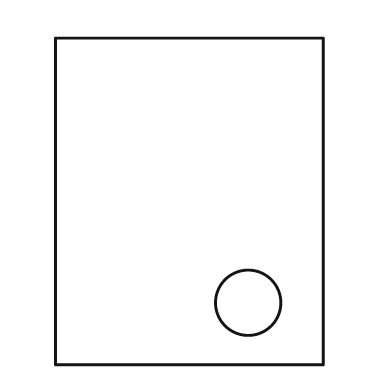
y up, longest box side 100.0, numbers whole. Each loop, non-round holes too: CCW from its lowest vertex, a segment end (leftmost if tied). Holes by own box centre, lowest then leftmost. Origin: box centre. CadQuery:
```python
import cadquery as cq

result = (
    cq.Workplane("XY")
    .moveTo(-41.0, -50.0)
    .lineTo(41.0, -50.0)
    .lineTo(41.0, 50.0)
    .lineTo(-41.0, 50.0)
    .close()
    .moveTo(18.0, -31.0)
    .circle(10.0)
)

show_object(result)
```